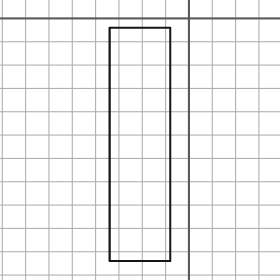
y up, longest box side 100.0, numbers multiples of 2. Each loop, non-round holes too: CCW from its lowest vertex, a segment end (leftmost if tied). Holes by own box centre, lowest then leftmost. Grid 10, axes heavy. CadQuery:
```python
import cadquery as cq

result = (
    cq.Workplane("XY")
    .moveTo(-34.0, -104.0)
    .lineTo(-8.0, -104.0)
    .lineTo(-8.0, -4.0)
    .lineTo(-34.0, -4.0)
    .close()
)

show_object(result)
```